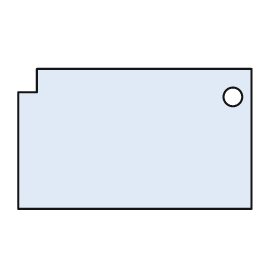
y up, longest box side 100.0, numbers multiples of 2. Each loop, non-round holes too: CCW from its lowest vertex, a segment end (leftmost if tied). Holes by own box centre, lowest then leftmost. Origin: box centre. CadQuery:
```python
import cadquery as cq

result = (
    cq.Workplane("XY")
    .moveTo(-50.0, -30.0)
    .lineTo(50.0, -30.0)
    .lineTo(50.0, 30.0)
    .lineTo(-42.0, 30.0)
    .lineTo(-42.0, 20.0)
    .lineTo(-50.0, 20.0)
    .close()
    .moveTo(42.0, 18.0)
    .circle(4.0)
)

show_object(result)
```